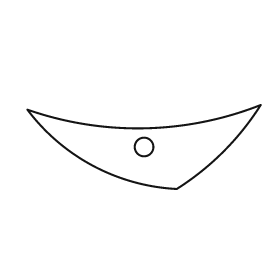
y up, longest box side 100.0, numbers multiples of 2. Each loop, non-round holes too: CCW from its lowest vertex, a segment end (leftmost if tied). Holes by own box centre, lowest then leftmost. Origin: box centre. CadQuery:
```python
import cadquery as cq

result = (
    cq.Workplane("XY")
    .moveTo(14.0, -18.0)
    .threePointArc((34.0, -2.0), (50.0, 18.0))
    .threePointArc((0.0, 8.0), (-50.0, 16.0))
    .threePointArc((-22.0, -8.0), (14.0, -18.0))
    .close()
    .moveTo(0.0, 0.0)
    .circle(4.0)
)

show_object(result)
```